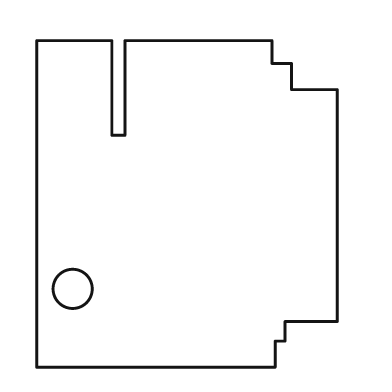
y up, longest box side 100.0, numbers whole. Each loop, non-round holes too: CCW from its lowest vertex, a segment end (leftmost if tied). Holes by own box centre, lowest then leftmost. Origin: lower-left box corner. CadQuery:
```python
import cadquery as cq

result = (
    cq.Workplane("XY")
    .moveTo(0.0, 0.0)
    .lineTo(73.0, 0.0)
    .lineTo(73.0, 8.0)
    .lineTo(76.0, 8.0)
    .lineTo(76.0, 14.0)
    .lineTo(92.0, 14.0)
    .lineTo(92.0, 85.0)
    .lineTo(78.0, 85.0)
    .lineTo(78.0, 93.0)
    .lineTo(72.0, 93.0)
    .lineTo(72.0, 100.0)
    .lineTo(27.0, 100.0)
    .lineTo(27.0, 71.0)
    .lineTo(23.0, 71.0)
    .lineTo(23.0, 100.0)
    .lineTo(0.0, 100.0)
    .close()
    .moveTo(11.0, 24.0)
    .circle(6.0)
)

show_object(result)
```